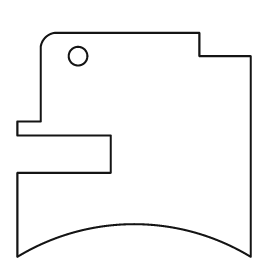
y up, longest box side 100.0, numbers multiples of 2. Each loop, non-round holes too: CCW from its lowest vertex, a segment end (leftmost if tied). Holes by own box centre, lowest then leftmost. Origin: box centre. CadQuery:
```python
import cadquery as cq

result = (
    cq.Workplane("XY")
    .moveTo(-50.0, -48.0)
    .threePointArc((0.0, -34.0), (50.0, -48.0))
    .lineTo(50.0, 38.0)
    .lineTo(28.0, 38.0)
    .lineTo(28.0, 48.0)
    .lineTo(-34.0, 48.0)
    .threePointArc((-38.0, 46.0), (-40.0, 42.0))
    .lineTo(-40.0, 10.0)
    .lineTo(-50.0, 10.0)
    .lineTo(-50.0, 4.0)
    .lineTo(-10.0, 4.0)
    .lineTo(-10.0, -12.0)
    .lineTo(-50.0, -12.0)
    .close()
    .moveTo(-24.0, 38.0)
    .circle(4.0)
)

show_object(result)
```